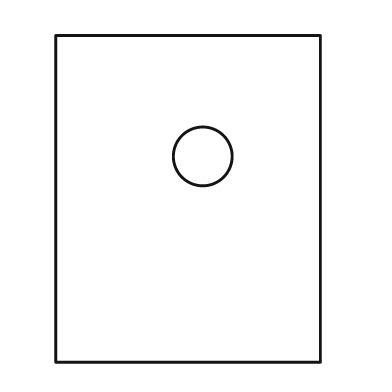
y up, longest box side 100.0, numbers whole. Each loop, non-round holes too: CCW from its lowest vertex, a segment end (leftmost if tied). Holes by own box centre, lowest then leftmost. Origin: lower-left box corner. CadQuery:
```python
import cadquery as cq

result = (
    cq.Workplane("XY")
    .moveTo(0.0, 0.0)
    .lineTo(81.0, 0.0)
    .lineTo(81.0, 100.0)
    .lineTo(0.0, 100.0)
    .close()
    .moveTo(45.0, 63.0)
    .circle(9.0)
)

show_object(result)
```